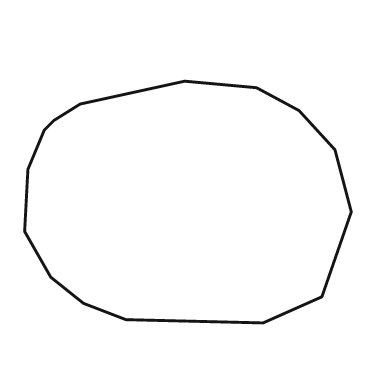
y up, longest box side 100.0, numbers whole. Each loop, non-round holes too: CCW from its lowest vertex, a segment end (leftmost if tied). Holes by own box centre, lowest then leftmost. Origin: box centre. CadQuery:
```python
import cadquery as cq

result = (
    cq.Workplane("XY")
    .moveTo(23.0, -37.0)
    .lineTo(41.0, -29.0)
    .lineTo(50.0, -3.0)
    .lineTo(45.0, 16.0)
    .lineTo(34.0, 28.0)
    .lineTo(21.0, 35.0)
    .lineTo(-1.0, 37.0)
    .lineTo(-33.0, 30.0)
    .lineTo(-41.0, 25.0)
    .lineTo(-44.0, 22.0)
    .lineTo(-49.0, 10.0)
    .lineTo(-50.0, -9.0)
    .lineTo(-42.0, -23.0)
    .lineTo(-32.0, -31.0)
    .lineTo(-19.0, -36.0)
    .close()
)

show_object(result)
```